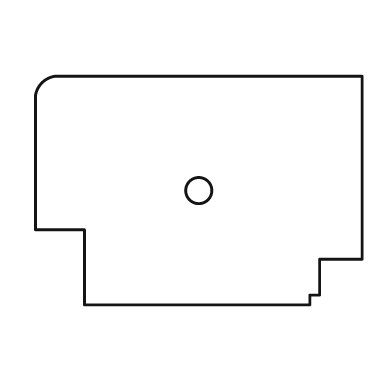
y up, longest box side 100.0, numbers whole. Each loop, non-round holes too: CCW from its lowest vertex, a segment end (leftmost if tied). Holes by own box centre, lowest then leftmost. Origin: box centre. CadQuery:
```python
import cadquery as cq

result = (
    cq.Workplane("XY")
    .moveTo(-35.0, -35.0)
    .lineTo(34.0, -35.0)
    .lineTo(34.0, -32.0)
    .lineTo(37.0, -32.0)
    .lineTo(37.0, -21.0)
    .lineTo(50.0, -21.0)
    .lineTo(50.0, 35.0)
    .lineTo(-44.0, 35.0)
    .threePointArc((-48.0, 33.0), (-50.0, 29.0))
    .lineTo(-50.0, -12.0)
    .lineTo(-35.0, -12.0)
    .close()
    .moveTo(0.0, 0.0)
    .circle(4.0)
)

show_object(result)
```